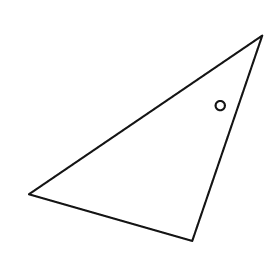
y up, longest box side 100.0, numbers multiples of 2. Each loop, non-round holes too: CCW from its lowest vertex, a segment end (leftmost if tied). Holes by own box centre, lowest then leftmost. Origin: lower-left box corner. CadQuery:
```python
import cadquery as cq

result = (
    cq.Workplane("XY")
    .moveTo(70.0, 0.0)
    .lineTo(100.0, 88.0)
    .lineTo(0.0, 20.0)
    .close()
    .moveTo(82.0, 58.0)
    .circle(2.0)
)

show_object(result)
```